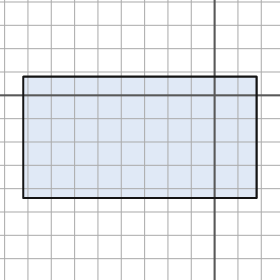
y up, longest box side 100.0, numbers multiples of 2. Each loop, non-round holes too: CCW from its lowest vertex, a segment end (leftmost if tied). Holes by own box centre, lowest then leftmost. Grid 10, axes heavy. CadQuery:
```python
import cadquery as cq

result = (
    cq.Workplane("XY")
    .moveTo(-82.0, -44.0)
    .lineTo(18.0, -44.0)
    .lineTo(18.0, 8.0)
    .lineTo(-82.0, 8.0)
    .close()
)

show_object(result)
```